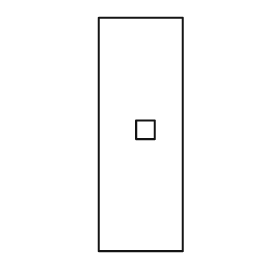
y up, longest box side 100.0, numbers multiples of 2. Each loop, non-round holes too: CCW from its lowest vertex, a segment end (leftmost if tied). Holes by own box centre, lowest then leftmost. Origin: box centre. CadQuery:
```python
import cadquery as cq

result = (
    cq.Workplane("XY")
    .moveTo(-18.0, -50.0)
    .lineTo(18.0, -50.0)
    .lineTo(18.0, 50.0)
    .lineTo(-18.0, 50.0)
    .close()
    .moveTo(-2.0, -2.0)
    .lineTo(6.0, -2.0)
    .lineTo(6.0, 6.0)
    .lineTo(-2.0, 6.0)
    .close()
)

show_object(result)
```